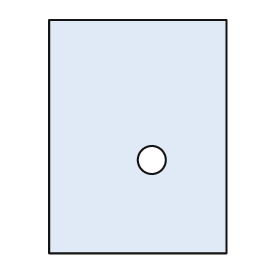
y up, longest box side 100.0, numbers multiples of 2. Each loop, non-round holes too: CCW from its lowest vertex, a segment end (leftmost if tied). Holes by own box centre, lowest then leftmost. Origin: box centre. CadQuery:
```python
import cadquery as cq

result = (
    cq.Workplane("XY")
    .moveTo(-38.0, -50.0)
    .lineTo(38.0, -50.0)
    .lineTo(38.0, 50.0)
    .lineTo(-38.0, 50.0)
    .close()
    .moveTo(6.0, -10.0)
    .circle(6.0)
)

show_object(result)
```